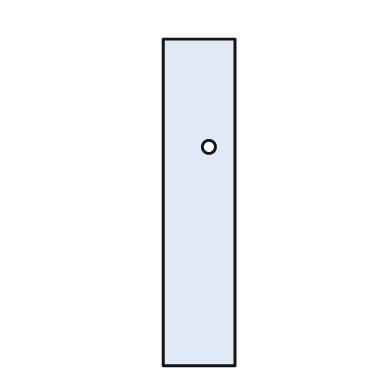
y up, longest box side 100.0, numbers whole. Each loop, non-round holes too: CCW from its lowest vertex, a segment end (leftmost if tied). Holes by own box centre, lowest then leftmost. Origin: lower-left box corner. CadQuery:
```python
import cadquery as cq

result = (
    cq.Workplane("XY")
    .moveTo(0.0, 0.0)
    .lineTo(22.0, 0.0)
    .lineTo(22.0, 100.0)
    .lineTo(0.0, 100.0)
    .close()
    .moveTo(14.0, 67.0)
    .circle(2.0)
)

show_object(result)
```